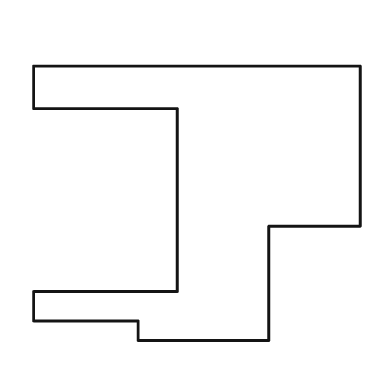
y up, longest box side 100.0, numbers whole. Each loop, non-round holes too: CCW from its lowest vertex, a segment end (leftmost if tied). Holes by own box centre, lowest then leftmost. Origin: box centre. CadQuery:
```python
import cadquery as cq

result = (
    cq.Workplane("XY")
    .moveTo(-18.0, -42.0)
    .lineTo(22.0, -42.0)
    .lineTo(22.0, -7.0)
    .lineTo(50.0, -7.0)
    .lineTo(50.0, 42.0)
    .lineTo(-50.0, 42.0)
    .lineTo(-50.0, 29.0)
    .lineTo(-6.0, 29.0)
    .lineTo(-6.0, -27.0)
    .lineTo(-50.0, -27.0)
    .lineTo(-50.0, -36.0)
    .lineTo(-18.0, -36.0)
    .close()
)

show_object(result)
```